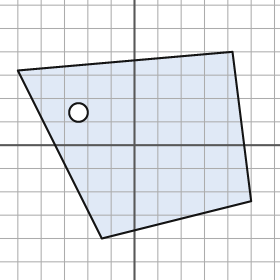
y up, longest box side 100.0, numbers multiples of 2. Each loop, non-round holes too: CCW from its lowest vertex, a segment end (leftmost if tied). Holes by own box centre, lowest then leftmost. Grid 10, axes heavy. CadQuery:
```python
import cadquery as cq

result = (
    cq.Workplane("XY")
    .moveTo(-14.0, -40.0)
    .lineTo(50.0, -24.0)
    .lineTo(42.0, 40.0)
    .lineTo(-50.0, 32.0)
    .close()
    .moveTo(-24.0, 14.0)
    .circle(4.0)
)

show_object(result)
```